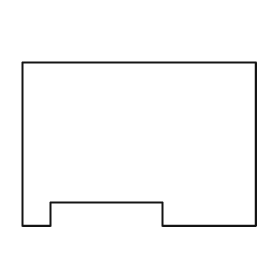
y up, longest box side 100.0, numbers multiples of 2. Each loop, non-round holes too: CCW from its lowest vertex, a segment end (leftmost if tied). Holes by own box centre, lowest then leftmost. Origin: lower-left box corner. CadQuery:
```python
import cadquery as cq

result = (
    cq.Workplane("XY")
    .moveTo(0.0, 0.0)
    .lineTo(12.0, 0.0)
    .lineTo(12.0, 10.0)
    .lineTo(60.0, 10.0)
    .lineTo(60.0, 0.0)
    .lineTo(100.0, 0.0)
    .lineTo(100.0, 70.0)
    .lineTo(0.0, 70.0)
    .close()
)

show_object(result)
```